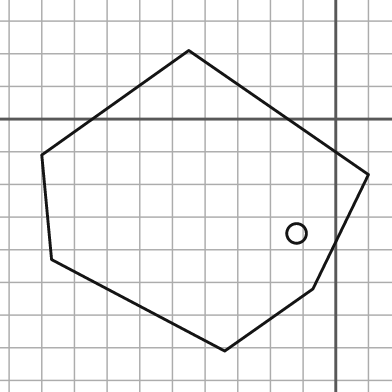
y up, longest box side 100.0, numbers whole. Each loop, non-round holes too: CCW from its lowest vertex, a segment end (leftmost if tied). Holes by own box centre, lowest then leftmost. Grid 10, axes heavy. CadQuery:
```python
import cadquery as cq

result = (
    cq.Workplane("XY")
    .moveTo(-34.0, -71.0)
    .lineTo(-7.0, -52.0)
    .lineTo(10.0, -17.0)
    .lineTo(-45.0, 21.0)
    .lineTo(-90.0, -11.0)
    .lineTo(-87.0, -43.0)
    .close()
    .moveTo(-12.0, -35.0)
    .circle(3.0)
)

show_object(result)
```